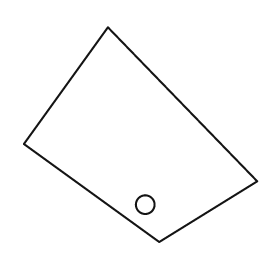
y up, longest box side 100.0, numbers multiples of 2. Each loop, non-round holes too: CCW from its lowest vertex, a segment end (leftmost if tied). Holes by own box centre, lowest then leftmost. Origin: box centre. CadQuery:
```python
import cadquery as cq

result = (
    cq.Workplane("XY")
    .moveTo(8.0, -46.0)
    .lineTo(50.0, -20.0)
    .lineTo(-14.0, 46.0)
    .lineTo(-50.0, -4.0)
    .close()
    .moveTo(2.0, -30.0)
    .circle(4.0)
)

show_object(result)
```